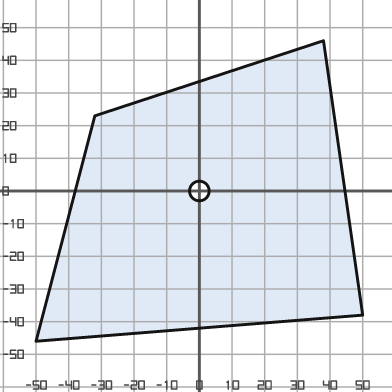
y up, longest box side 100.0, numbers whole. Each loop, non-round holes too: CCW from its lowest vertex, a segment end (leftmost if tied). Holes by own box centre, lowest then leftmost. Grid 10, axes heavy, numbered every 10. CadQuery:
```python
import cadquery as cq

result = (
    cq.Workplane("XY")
    .moveTo(-50.0, -46.0)
    .lineTo(50.0, -38.0)
    .lineTo(38.0, 46.0)
    .lineTo(-32.0, 23.0)
    .close()
    .moveTo(0.0, 0.0)
    .circle(3.0)
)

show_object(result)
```